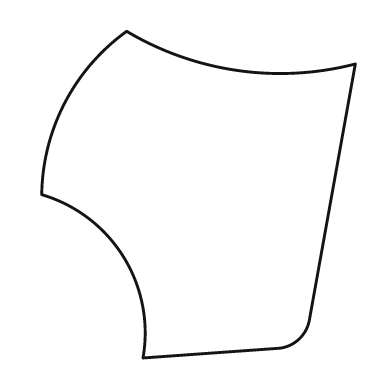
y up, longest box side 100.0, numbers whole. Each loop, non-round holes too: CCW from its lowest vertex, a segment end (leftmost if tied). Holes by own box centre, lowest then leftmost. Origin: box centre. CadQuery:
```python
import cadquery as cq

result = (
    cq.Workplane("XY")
    .moveTo(-17.0, -50.0)
    .lineTo(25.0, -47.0)
    .threePointArc((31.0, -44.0), (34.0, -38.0))
    .lineTo(48.0, 40.0)
    .threePointArc((12.0, 38.0), (-22.0, 50.0))
    .threePointArc((-41.0, 28.0), (-48.0, 0.0))
    .threePointArc((-23.0, -19.0), (-17.0, -50.0))
    .close()
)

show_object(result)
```